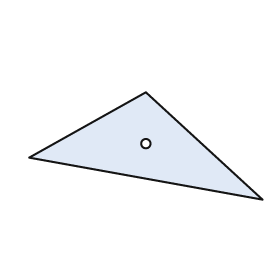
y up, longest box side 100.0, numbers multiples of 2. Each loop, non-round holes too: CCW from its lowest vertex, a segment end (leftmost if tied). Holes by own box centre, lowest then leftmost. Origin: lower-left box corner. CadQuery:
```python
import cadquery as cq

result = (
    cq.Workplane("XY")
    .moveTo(100.0, 0.0)
    .lineTo(50.0, 46.0)
    .lineTo(0.0, 18.0)
    .close()
    .moveTo(50.0, 24.0)
    .circle(2.0)
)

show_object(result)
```